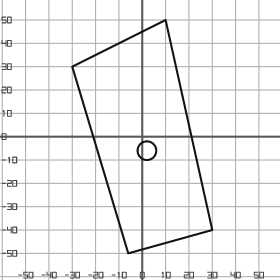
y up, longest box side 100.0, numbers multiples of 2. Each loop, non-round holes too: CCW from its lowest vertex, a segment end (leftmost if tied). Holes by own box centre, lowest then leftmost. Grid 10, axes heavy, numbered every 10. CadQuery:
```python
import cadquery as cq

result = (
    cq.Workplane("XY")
    .moveTo(-6.0, -50.0)
    .lineTo(30.0, -40.0)
    .lineTo(10.0, 50.0)
    .lineTo(-30.0, 30.0)
    .close()
    .moveTo(2.0, -6.0)
    .circle(4.0)
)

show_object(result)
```